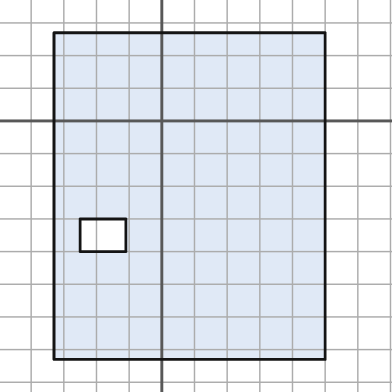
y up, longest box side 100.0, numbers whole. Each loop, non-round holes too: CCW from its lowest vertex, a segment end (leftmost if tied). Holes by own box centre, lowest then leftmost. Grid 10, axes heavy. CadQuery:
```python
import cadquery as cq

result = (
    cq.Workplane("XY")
    .moveTo(-33.0, -73.0)
    .lineTo(50.0, -73.0)
    .lineTo(50.0, 27.0)
    .lineTo(-33.0, 27.0)
    .close()
    .moveTo(-25.0, -40.0)
    .lineTo(-11.0, -40.0)
    .lineTo(-11.0, -30.0)
    .lineTo(-25.0, -30.0)
    .close()
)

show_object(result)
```